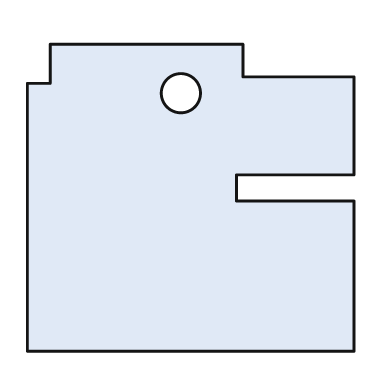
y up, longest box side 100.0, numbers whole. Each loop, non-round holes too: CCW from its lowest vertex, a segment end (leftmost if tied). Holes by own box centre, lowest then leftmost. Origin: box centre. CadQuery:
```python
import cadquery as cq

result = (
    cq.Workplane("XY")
    .moveTo(-50.0, -47.0)
    .lineTo(50.0, -47.0)
    .lineTo(50.0, -1.0)
    .lineTo(14.0, -1.0)
    .lineTo(14.0, 7.0)
    .lineTo(50.0, 7.0)
    .lineTo(50.0, 37.0)
    .lineTo(16.0, 37.0)
    .lineTo(16.0, 47.0)
    .lineTo(-43.0, 47.0)
    .lineTo(-43.0, 35.0)
    .lineTo(-50.0, 35.0)
    .close()
    .moveTo(-3.0, 32.0)
    .circle(6.0)
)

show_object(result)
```